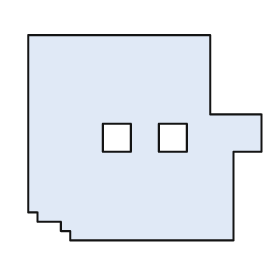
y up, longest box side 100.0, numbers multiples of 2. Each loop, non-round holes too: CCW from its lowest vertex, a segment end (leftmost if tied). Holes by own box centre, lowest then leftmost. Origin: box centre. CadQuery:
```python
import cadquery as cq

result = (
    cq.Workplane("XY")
    .moveTo(-32.0, -44.0)
    .lineTo(38.0, -44.0)
    .lineTo(38.0, -6.0)
    .lineTo(50.0, -6.0)
    .lineTo(50.0, 10.0)
    .lineTo(28.0, 10.0)
    .lineTo(28.0, 44.0)
    .lineTo(-50.0, 44.0)
    .lineTo(-50.0, -32.0)
    .lineTo(-46.0, -32.0)
    .lineTo(-46.0, -36.0)
    .lineTo(-36.0, -36.0)
    .lineTo(-36.0, -40.0)
    .lineTo(-32.0, -40.0)
    .close()
    .moveTo(-18.0, -6.0)
    .lineTo(-6.0, -6.0)
    .lineTo(-6.0, 6.0)
    .lineTo(-18.0, 6.0)
    .close()
    .moveTo(6.0, -6.0)
    .lineTo(18.0, -6.0)
    .lineTo(18.0, 6.0)
    .lineTo(6.0, 6.0)
    .close()
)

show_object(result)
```